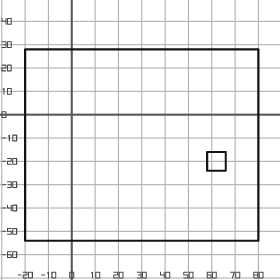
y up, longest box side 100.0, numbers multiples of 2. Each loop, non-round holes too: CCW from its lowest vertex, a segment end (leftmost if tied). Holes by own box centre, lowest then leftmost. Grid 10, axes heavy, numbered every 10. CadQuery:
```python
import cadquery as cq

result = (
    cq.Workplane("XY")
    .moveTo(-20.0, -54.0)
    .lineTo(80.0, -54.0)
    .lineTo(80.0, 28.0)
    .lineTo(-20.0, 28.0)
    .close()
    .moveTo(58.0, -24.0)
    .lineTo(66.0, -24.0)
    .lineTo(66.0, -16.0)
    .lineTo(58.0, -16.0)
    .close()
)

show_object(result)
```